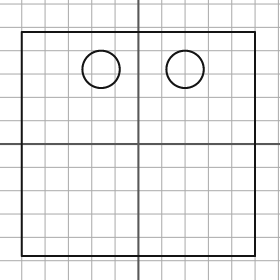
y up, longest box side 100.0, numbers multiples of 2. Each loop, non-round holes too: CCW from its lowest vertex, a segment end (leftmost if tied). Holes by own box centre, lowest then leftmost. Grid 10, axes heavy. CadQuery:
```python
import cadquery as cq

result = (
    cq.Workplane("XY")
    .moveTo(-50.0, -48.0)
    .lineTo(50.0, -48.0)
    .lineTo(50.0, 48.0)
    .lineTo(-50.0, 48.0)
    .close()
    .moveTo(-16.0, 32.0)
    .circle(8.0)
    .moveTo(20.0, 32.0)
    .circle(8.0)
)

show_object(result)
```